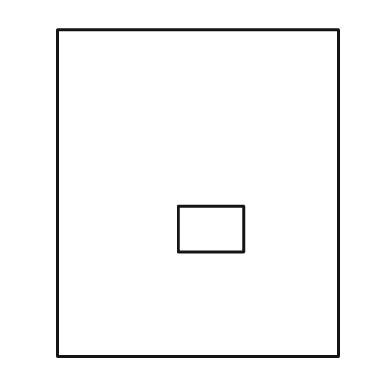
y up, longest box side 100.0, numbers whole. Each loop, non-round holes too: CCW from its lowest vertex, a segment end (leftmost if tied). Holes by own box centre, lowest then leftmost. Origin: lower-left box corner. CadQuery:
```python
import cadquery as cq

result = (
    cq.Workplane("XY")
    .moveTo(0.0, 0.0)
    .lineTo(86.0, 0.0)
    .lineTo(86.0, 100.0)
    .lineTo(0.0, 100.0)
    .close()
    .moveTo(37.0, 32.0)
    .lineTo(57.0, 32.0)
    .lineTo(57.0, 46.0)
    .lineTo(37.0, 46.0)
    .close()
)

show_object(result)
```